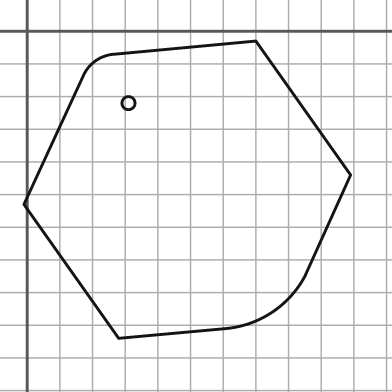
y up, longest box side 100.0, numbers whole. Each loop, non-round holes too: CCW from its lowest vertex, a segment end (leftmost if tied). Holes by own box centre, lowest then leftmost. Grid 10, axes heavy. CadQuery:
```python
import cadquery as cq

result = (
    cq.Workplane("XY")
    .moveTo(28.0, -94.0)
    .lineTo(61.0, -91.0)
    .threePointArc((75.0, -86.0), (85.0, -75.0))
    .lineTo(99.0, -44.0)
    .lineTo(70.0, -3.0)
    .lineTo(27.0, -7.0)
    .threePointArc((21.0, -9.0), (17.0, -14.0))
    .lineTo(-1.0, -53.0)
    .close()
    .moveTo(31.0, -22.0)
    .circle(2.0)
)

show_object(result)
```